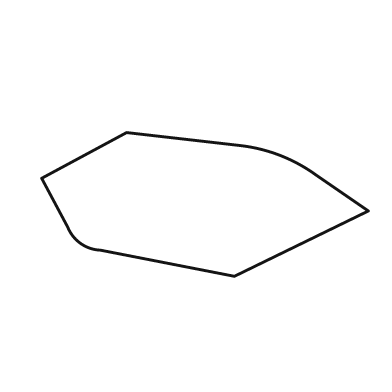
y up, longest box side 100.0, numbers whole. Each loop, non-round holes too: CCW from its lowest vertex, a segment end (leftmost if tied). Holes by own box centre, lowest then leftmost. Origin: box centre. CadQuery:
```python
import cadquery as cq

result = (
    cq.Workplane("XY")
    .moveTo(9.0, -22.0)
    .lineTo(50.0, -2.0)
    .lineTo(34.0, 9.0)
    .threePointArc((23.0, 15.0), (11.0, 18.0))
    .lineTo(-24.0, 22.0)
    .lineTo(-50.0, 8.0)
    .lineTo(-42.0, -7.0)
    .threePointArc((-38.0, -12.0), (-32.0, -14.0))
    .close()
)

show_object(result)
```